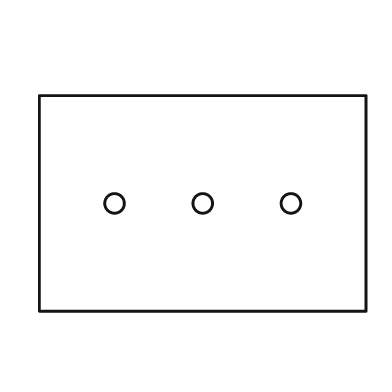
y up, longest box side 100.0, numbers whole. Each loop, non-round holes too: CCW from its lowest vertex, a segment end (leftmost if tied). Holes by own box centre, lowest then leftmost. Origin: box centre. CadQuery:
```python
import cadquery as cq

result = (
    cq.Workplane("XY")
    .moveTo(-50.0, -33.0)
    .lineTo(50.0, -33.0)
    .lineTo(50.0, 33.0)
    .lineTo(-50.0, 33.0)
    .close()
    .moveTo(-27.0, 0.0)
    .circle(3.0)
    .moveTo(0.0, 0.0)
    .circle(3.0)
    .moveTo(27.0, 0.0)
    .circle(3.0)
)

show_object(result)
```